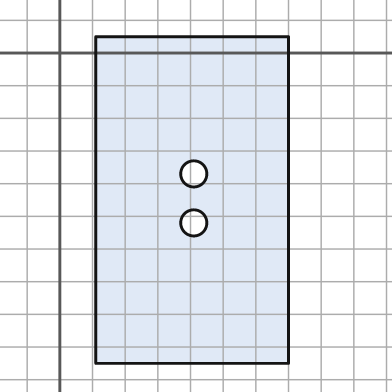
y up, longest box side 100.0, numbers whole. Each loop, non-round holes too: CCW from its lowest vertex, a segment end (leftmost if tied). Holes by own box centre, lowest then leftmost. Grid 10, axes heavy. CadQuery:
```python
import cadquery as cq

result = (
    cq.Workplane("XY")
    .moveTo(11.0, -95.0)
    .lineTo(70.0, -95.0)
    .lineTo(70.0, 5.0)
    .lineTo(11.0, 5.0)
    .close()
    .moveTo(41.0, -52.0)
    .circle(4.0)
    .moveTo(41.0, -37.0)
    .circle(4.0)
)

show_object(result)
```